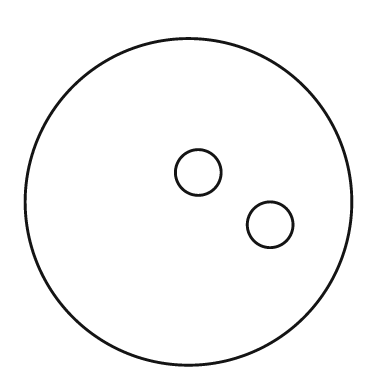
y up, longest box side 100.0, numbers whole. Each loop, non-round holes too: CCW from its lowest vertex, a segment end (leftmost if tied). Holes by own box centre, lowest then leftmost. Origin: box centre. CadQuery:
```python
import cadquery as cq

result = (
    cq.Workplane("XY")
    .moveTo(0.0, 0.0)
    .circle(50.0)
    .moveTo(25.0, -7.0)
    .circle(7.0)
    .moveTo(3.0, 9.0)
    .circle(7.0)
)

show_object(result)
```